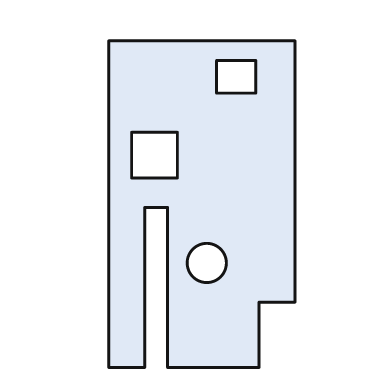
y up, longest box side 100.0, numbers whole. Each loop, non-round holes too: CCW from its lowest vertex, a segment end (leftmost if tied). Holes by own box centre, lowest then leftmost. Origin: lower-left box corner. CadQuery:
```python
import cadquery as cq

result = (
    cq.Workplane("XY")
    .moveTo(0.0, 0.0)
    .lineTo(11.0, 0.0)
    .lineTo(11.0, 49.0)
    .lineTo(18.0, 49.0)
    .lineTo(18.0, 0.0)
    .lineTo(46.0, 0.0)
    .lineTo(46.0, 20.0)
    .lineTo(57.0, 20.0)
    .lineTo(57.0, 100.0)
    .lineTo(0.0, 100.0)
    .close()
    .moveTo(30.0, 32.0)
    .circle(6.0)
    .moveTo(7.0, 58.0)
    .lineTo(21.0, 58.0)
    .lineTo(21.0, 72.0)
    .lineTo(7.0, 72.0)
    .close()
    .moveTo(33.0, 84.0)
    .lineTo(45.0, 84.0)
    .lineTo(45.0, 94.0)
    .lineTo(33.0, 94.0)
    .close()
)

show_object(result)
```